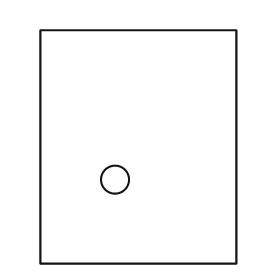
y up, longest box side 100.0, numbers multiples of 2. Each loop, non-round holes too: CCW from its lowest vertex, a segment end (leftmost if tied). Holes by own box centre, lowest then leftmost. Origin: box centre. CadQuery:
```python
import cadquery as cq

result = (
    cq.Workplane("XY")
    .moveTo(-42.0, -50.0)
    .lineTo(42.0, -50.0)
    .lineTo(42.0, 50.0)
    .lineTo(-42.0, 50.0)
    .close()
    .moveTo(-10.0, -14.0)
    .circle(6.0)
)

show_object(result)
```